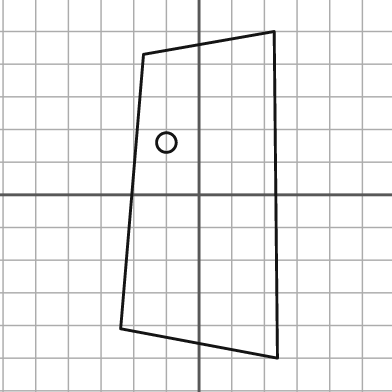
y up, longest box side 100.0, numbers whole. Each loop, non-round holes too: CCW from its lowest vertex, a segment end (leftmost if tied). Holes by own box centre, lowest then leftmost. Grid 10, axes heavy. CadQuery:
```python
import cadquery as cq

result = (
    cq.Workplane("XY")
    .moveTo(24.0, -50.0)
    .lineTo(23.0, 50.0)
    .lineTo(-17.0, 43.0)
    .lineTo(-24.0, -41.0)
    .close()
    .moveTo(-10.0, 16.0)
    .circle(3.0)
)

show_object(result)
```